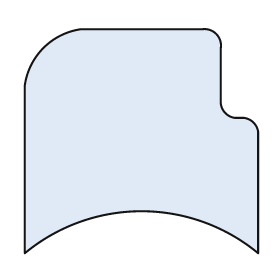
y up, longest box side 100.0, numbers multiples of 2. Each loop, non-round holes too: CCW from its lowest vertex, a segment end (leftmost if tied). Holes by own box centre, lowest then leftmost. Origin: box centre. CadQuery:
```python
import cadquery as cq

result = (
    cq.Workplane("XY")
    .moveTo(-50.0, -48.0)
    .threePointArc((0.0, -30.0), (50.0, -48.0))
    .lineTo(50.0, 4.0)
    .threePointArc((48.0, 8.0), (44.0, 10.0))
    .lineTo(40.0, 10.0)
    .threePointArc((36.0, 12.0), (34.0, 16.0))
    .lineTo(34.0, 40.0)
    .threePointArc((32.0, 46.0), (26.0, 48.0))
    .lineTo(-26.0, 48.0)
    .threePointArc((-42.0, 40.0), (-50.0, 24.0))
    .close()
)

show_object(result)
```